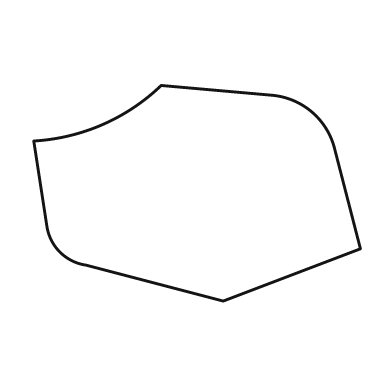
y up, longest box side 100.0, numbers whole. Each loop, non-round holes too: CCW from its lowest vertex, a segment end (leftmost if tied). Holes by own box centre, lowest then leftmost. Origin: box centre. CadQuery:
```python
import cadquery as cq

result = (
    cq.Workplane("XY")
    .moveTo(8.0, -33.0)
    .lineTo(50.0, -17.0)
    .lineTo(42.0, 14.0)
    .threePointArc((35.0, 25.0), (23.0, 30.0))
    .lineTo(-11.0, 33.0)
    .threePointArc((-29.0, 21.0), (-50.0, 16.0))
    .lineTo(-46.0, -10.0)
    .threePointArc((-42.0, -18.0), (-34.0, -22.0))
    .close()
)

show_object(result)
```